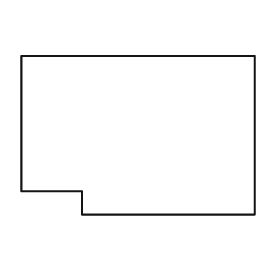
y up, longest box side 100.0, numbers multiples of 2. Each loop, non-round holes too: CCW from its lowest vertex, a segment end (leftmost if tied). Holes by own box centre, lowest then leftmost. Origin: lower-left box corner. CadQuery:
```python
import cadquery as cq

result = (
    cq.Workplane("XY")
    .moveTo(26.0, 0.0)
    .lineTo(100.0, 0.0)
    .lineTo(100.0, 68.0)
    .lineTo(0.0, 68.0)
    .lineTo(0.0, 10.0)
    .lineTo(26.0, 10.0)
    .close()
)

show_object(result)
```